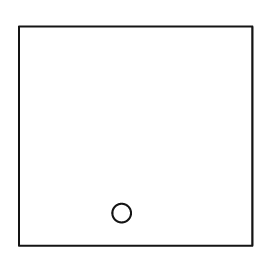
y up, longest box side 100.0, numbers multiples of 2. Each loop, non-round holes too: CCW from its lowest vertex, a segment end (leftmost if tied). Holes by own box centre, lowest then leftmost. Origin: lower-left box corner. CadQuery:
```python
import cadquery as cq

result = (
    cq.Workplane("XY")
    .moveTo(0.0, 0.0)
    .lineTo(100.0, 0.0)
    .lineTo(100.0, 94.0)
    .lineTo(0.0, 94.0)
    .close()
    .moveTo(44.0, 14.0)
    .circle(4.0)
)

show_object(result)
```